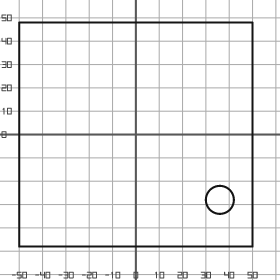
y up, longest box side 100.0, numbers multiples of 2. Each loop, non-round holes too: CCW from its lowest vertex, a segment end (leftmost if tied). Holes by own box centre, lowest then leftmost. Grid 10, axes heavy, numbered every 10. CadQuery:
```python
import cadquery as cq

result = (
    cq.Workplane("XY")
    .moveTo(-50.0, -48.0)
    .lineTo(50.0, -48.0)
    .lineTo(50.0, 48.0)
    .lineTo(-50.0, 48.0)
    .close()
    .moveTo(36.0, -28.0)
    .circle(6.0)
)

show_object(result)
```